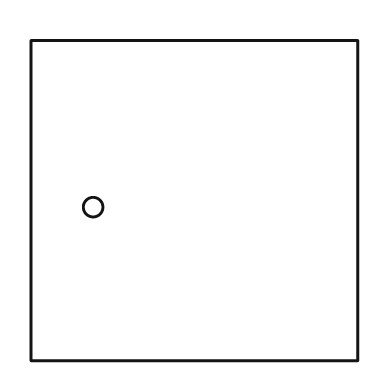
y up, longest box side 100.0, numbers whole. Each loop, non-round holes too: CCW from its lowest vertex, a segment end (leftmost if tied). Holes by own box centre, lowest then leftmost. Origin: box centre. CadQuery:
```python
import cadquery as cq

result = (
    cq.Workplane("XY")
    .moveTo(-50.0, -49.0)
    .lineTo(50.0, -49.0)
    .lineTo(50.0, 49.0)
    .lineTo(-50.0, 49.0)
    .close()
    .moveTo(-31.0, -2.0)
    .circle(3.0)
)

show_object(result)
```